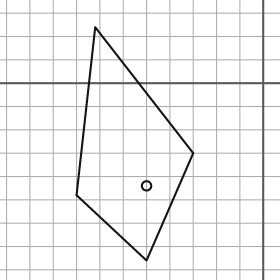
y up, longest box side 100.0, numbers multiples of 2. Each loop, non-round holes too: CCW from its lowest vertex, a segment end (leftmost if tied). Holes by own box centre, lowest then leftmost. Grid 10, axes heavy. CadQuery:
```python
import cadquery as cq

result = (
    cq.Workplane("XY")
    .moveTo(-50.0, -76.0)
    .lineTo(-30.0, -30.0)
    .lineTo(-72.0, 24.0)
    .lineTo(-80.0, -48.0)
    .close()
    .moveTo(-50.0, -44.0)
    .circle(2.0)
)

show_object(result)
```